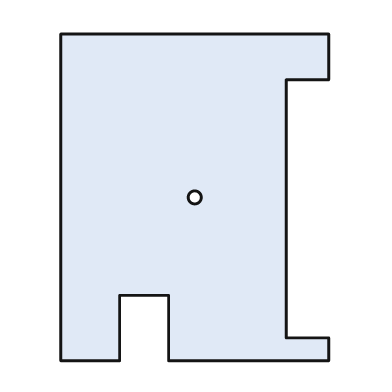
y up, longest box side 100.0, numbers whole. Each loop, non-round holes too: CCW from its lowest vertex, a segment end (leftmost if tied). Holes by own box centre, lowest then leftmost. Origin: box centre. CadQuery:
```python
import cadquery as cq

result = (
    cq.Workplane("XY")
    .moveTo(-41.0, -50.0)
    .lineTo(-23.0, -50.0)
    .lineTo(-23.0, -30.0)
    .lineTo(-8.0, -30.0)
    .lineTo(-8.0, -50.0)
    .lineTo(41.0, -50.0)
    .lineTo(41.0, -43.0)
    .lineTo(28.0, -43.0)
    .lineTo(28.0, 36.0)
    .lineTo(41.0, 36.0)
    .lineTo(41.0, 50.0)
    .lineTo(-41.0, 50.0)
    .close()
    .moveTo(0.0, 0.0)
    .circle(2.0)
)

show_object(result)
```